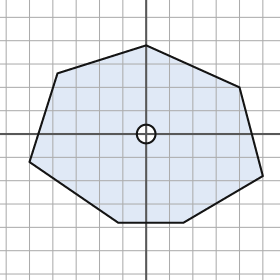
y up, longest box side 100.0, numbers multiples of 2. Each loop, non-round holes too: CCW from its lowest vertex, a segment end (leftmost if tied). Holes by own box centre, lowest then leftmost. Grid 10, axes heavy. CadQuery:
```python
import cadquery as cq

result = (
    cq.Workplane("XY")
    .moveTo(-12.0, -38.0)
    .lineTo(16.0, -38.0)
    .lineTo(50.0, -18.0)
    .lineTo(40.0, 20.0)
    .lineTo(0.0, 38.0)
    .lineTo(-38.0, 26.0)
    .lineTo(-50.0, -12.0)
    .close()
    .moveTo(0.0, 0.0)
    .circle(4.0)
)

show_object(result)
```